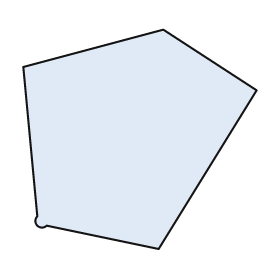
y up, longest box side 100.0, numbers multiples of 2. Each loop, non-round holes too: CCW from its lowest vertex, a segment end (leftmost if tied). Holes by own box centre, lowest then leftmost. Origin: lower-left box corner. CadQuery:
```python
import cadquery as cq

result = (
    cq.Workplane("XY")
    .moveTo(58.0, 0.0)
    .lineTo(100.0, 68.0)
    .lineTo(60.0, 94.0)
    .lineTo(0.0, 78.0)
    .lineTo(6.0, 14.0)
    .threePointArc((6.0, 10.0), (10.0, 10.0))
    .close()
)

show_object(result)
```